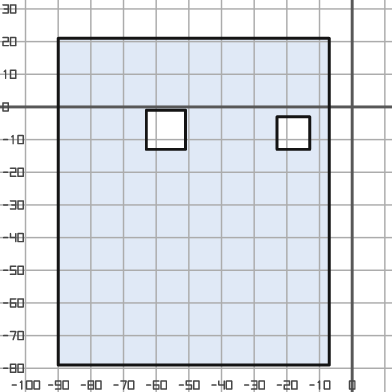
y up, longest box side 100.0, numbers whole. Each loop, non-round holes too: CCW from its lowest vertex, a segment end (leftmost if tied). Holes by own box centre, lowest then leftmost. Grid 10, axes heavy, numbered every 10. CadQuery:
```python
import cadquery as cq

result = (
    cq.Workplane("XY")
    .moveTo(-90.0, -79.0)
    .lineTo(-7.0, -79.0)
    .lineTo(-7.0, 21.0)
    .lineTo(-90.0, 21.0)
    .close()
    .moveTo(-23.0, -13.0)
    .lineTo(-13.0, -13.0)
    .lineTo(-13.0, -3.0)
    .lineTo(-23.0, -3.0)
    .close()
    .moveTo(-63.0, -13.0)
    .lineTo(-51.0, -13.0)
    .lineTo(-51.0, -1.0)
    .lineTo(-63.0, -1.0)
    .close()
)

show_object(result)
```